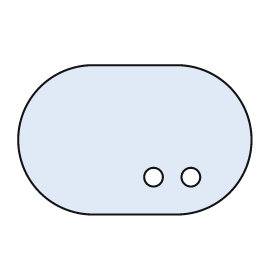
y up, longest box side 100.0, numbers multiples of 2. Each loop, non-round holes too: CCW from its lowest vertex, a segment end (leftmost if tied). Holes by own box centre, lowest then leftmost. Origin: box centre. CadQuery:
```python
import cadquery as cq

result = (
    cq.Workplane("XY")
    .moveTo(-18.0, -32.0)
    .lineTo(18.0, -32.0)
    .threePointArc((50.0, 0.0), (18.0, 32.0))
    .lineTo(-18.0, 32.0)
    .threePointArc((-50.0, 0.0), (-18.0, -32.0))
    .close()
    .moveTo(8.0, -16.0)
    .circle(4.0)
    .moveTo(24.0, -16.0)
    .circle(4.0)
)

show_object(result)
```